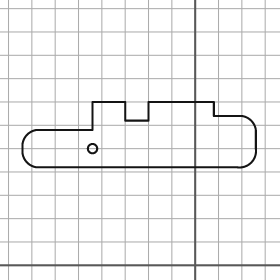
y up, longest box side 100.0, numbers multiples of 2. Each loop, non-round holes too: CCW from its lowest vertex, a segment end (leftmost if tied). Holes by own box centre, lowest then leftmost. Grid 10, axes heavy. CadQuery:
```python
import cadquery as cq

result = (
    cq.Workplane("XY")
    .moveTo(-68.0, 42.0)
    .lineTo(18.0, 42.0)
    .threePointArc((24.0, 44.0), (26.0, 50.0))
    .lineTo(26.0, 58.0)
    .threePointArc((24.0, 62.0), (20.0, 64.0))
    .lineTo(8.0, 64.0)
    .lineTo(8.0, 70.0)
    .lineTo(-20.0, 70.0)
    .lineTo(-20.0, 62.0)
    .lineTo(-30.0, 62.0)
    .lineTo(-30.0, 70.0)
    .lineTo(-44.0, 70.0)
    .lineTo(-44.0, 58.0)
    .lineTo(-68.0, 58.0)
    .threePointArc((-72.0, 56.0), (-74.0, 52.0))
    .lineTo(-74.0, 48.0)
    .threePointArc((-72.0, 44.0), (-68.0, 42.0))
    .close()
    .moveTo(-44.0, 50.0)
    .circle(2.0)
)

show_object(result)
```